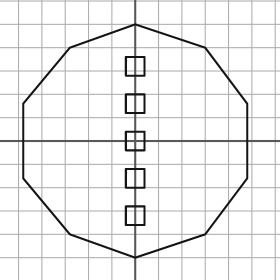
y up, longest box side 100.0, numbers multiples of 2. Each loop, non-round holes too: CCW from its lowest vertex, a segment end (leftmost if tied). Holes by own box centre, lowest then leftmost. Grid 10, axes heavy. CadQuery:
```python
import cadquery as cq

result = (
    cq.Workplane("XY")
    .moveTo(0.0, -50.0)
    .lineTo(30.0, -40.0)
    .lineTo(48.0, -16.0)
    .lineTo(48.0, 16.0)
    .lineTo(30.0, 40.0)
    .lineTo(0.0, 50.0)
    .lineTo(-28.0, 40.0)
    .lineTo(-48.0, 16.0)
    .lineTo(-48.0, -16.0)
    .lineTo(-28.0, -40.0)
    .close()
    .moveTo(-4.0, -36.0)
    .lineTo(4.0, -36.0)
    .lineTo(4.0, -28.0)
    .lineTo(-4.0, -28.0)
    .close()
    .moveTo(-4.0, -20.0)
    .lineTo(4.0, -20.0)
    .lineTo(4.0, -12.0)
    .lineTo(-4.0, -12.0)
    .close()
    .moveTo(-4.0, -4.0)
    .lineTo(4.0, -4.0)
    .lineTo(4.0, 4.0)
    .lineTo(-4.0, 4.0)
    .close()
    .moveTo(-4.0, 12.0)
    .lineTo(4.0, 12.0)
    .lineTo(4.0, 20.0)
    .lineTo(-4.0, 20.0)
    .close()
    .moveTo(-4.0, 28.0)
    .lineTo(4.0, 28.0)
    .lineTo(4.0, 36.0)
    .lineTo(-4.0, 36.0)
    .close()
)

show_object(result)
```